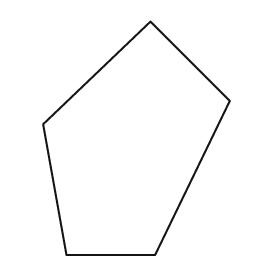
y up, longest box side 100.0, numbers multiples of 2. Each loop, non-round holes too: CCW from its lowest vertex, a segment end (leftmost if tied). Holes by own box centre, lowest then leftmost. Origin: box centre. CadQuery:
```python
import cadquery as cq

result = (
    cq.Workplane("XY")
    .moveTo(-30.0, -50.0)
    .lineTo(8.0, -50.0)
    .lineTo(40.0, 16.0)
    .lineTo(6.0, 50.0)
    .lineTo(-40.0, 6.0)
    .close()
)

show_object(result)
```